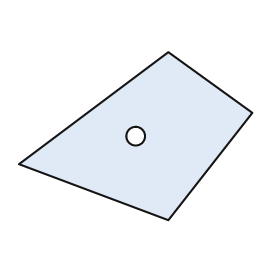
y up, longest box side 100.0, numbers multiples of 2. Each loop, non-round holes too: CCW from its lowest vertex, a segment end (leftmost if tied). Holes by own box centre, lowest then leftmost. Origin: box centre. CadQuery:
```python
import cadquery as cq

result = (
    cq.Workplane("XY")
    .moveTo(14.0, -36.0)
    .lineTo(50.0, 10.0)
    .lineTo(14.0, 36.0)
    .lineTo(-50.0, -12.0)
    .close()
    .moveTo(0.0, 0.0)
    .circle(4.0)
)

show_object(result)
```